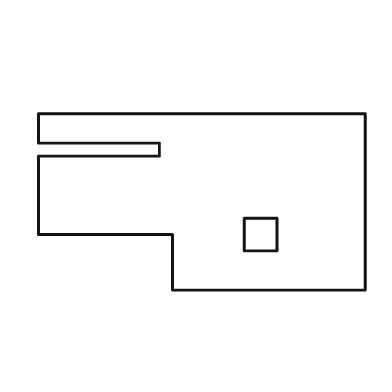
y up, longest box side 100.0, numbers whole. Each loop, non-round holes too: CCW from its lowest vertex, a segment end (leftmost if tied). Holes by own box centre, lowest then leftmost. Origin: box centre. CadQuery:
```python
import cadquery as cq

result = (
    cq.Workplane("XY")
    .moveTo(-9.0, -27.0)
    .lineTo(50.0, -27.0)
    .lineTo(50.0, 27.0)
    .lineTo(-50.0, 27.0)
    .lineTo(-50.0, 18.0)
    .lineTo(-13.0, 18.0)
    .lineTo(-13.0, 14.0)
    .lineTo(-50.0, 14.0)
    .lineTo(-50.0, -10.0)
    .lineTo(-9.0, -10.0)
    .close()
    .moveTo(13.0, -15.0)
    .lineTo(23.0, -15.0)
    .lineTo(23.0, -5.0)
    .lineTo(13.0, -5.0)
    .close()
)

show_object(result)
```